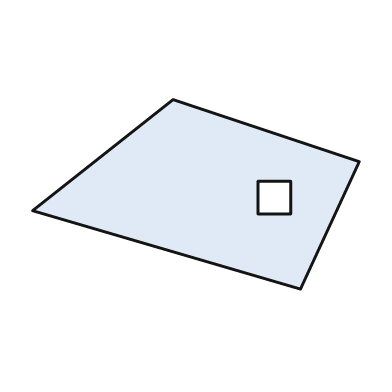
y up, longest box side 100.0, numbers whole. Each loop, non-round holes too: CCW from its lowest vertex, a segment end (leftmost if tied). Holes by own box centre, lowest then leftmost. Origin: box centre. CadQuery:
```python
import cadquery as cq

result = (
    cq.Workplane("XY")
    .moveTo(32.0, -29.0)
    .lineTo(50.0, 10.0)
    .lineTo(-7.0, 29.0)
    .lineTo(-50.0, -5.0)
    .close()
    .moveTo(19.0, -6.0)
    .lineTo(29.0, -6.0)
    .lineTo(29.0, 4.0)
    .lineTo(19.0, 4.0)
    .close()
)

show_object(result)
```